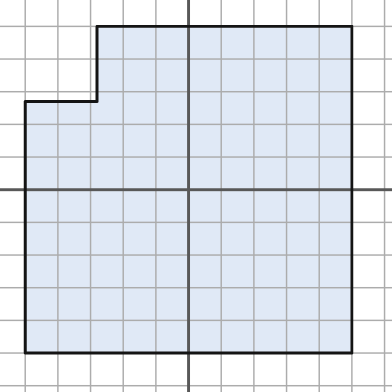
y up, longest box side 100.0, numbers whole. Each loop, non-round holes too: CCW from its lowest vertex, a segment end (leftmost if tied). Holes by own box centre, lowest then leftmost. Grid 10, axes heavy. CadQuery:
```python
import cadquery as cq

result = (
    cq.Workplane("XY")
    .moveTo(-50.0, -50.0)
    .lineTo(50.0, -50.0)
    .lineTo(50.0, 50.0)
    .lineTo(-28.0, 50.0)
    .lineTo(-28.0, 27.0)
    .lineTo(-50.0, 27.0)
    .close()
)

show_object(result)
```